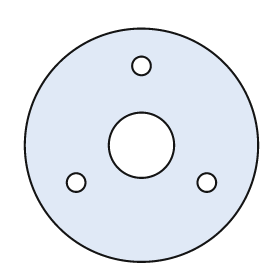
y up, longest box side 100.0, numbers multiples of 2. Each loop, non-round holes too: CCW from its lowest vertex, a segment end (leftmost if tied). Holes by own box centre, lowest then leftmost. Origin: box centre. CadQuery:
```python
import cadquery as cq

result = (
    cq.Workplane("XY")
    .moveTo(0.0, 0.0)
    .circle(50.0)
    .moveTo(-28.0, -16.0)
    .circle(4.0)
    .moveTo(28.0, -16.0)
    .circle(4.0)
    .moveTo(0.0, 0.0)
    .circle(14.0)
    .moveTo(0.0, 34.0)
    .circle(4.0)
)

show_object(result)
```